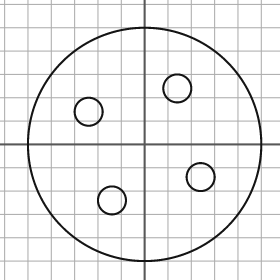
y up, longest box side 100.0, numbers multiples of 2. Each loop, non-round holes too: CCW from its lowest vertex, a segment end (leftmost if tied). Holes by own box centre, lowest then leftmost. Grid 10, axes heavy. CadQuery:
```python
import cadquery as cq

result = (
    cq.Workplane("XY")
    .moveTo(0.0, 0.0)
    .circle(50.0)
    .moveTo(-14.0, -24.0)
    .circle(6.0)
    .moveTo(24.0, -14.0)
    .circle(6.0)
    .moveTo(-24.0, 14.0)
    .circle(6.0)
    .moveTo(14.0, 24.0)
    .circle(6.0)
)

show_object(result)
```